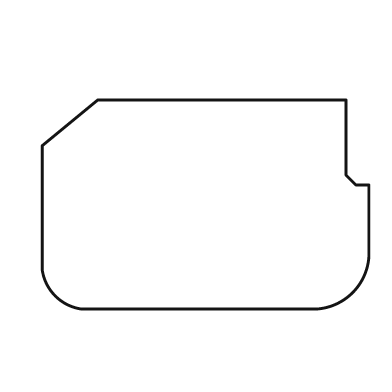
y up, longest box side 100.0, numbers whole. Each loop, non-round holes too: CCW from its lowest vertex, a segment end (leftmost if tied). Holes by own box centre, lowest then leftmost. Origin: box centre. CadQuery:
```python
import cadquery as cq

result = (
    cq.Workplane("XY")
    .moveTo(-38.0, -32.0)
    .lineTo(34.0, -32.0)
    .threePointArc((45.0, -27.0), (50.0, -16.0))
    .lineTo(50.0, 6.0)
    .lineTo(46.0, 6.0)
    .lineTo(43.0, 9.0)
    .lineTo(43.0, 32.0)
    .lineTo(-33.0, 32.0)
    .lineTo(-50.0, 18.0)
    .lineTo(-50.0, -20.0)
    .threePointArc((-46.0, -28.0), (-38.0, -32.0))
    .close()
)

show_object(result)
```